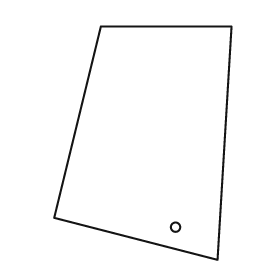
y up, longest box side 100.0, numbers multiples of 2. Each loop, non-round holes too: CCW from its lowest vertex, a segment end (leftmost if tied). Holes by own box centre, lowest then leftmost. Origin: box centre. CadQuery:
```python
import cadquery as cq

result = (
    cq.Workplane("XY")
    .moveTo(32.0, -50.0)
    .lineTo(38.0, 50.0)
    .lineTo(-18.0, 50.0)
    .lineTo(-38.0, -32.0)
    .close()
    .moveTo(14.0, -36.0)
    .circle(2.0)
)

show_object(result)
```